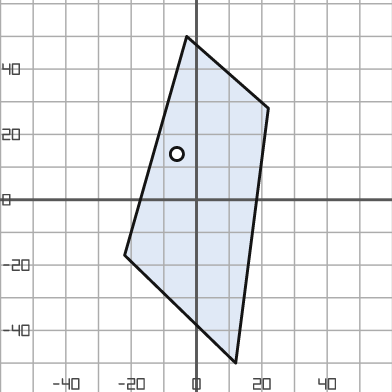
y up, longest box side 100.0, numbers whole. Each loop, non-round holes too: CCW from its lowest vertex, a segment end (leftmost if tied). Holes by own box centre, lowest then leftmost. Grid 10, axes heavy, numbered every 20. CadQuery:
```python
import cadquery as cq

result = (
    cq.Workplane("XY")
    .moveTo(12.0, -50.0)
    .lineTo(22.0, 28.0)
    .lineTo(-3.0, 50.0)
    .lineTo(-22.0, -17.0)
    .close()
    .moveTo(-6.0, 14.0)
    .circle(2.0)
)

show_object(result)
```